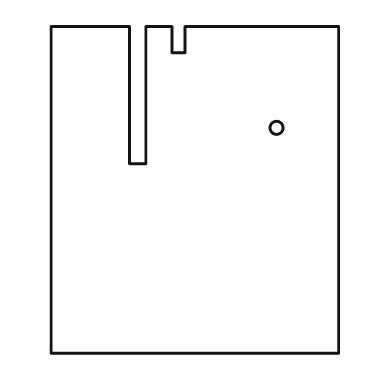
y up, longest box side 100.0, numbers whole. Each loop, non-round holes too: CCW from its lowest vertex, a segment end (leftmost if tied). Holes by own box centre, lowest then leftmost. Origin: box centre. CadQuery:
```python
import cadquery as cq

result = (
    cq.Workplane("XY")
    .moveTo(-44.0, -50.0)
    .lineTo(44.0, -50.0)
    .lineTo(44.0, 50.0)
    .lineTo(-3.0, 50.0)
    .lineTo(-3.0, 42.0)
    .lineTo(-7.0, 42.0)
    .lineTo(-7.0, 50.0)
    .lineTo(-15.0, 50.0)
    .lineTo(-15.0, 8.0)
    .lineTo(-20.0, 8.0)
    .lineTo(-20.0, 50.0)
    .lineTo(-44.0, 50.0)
    .close()
    .moveTo(25.0, 19.0)
    .circle(2.0)
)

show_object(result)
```